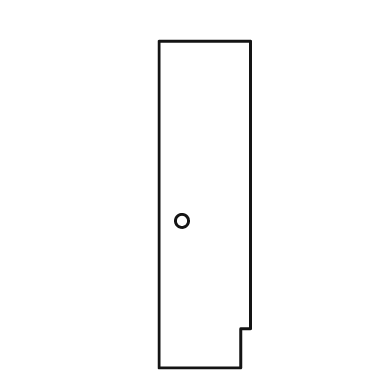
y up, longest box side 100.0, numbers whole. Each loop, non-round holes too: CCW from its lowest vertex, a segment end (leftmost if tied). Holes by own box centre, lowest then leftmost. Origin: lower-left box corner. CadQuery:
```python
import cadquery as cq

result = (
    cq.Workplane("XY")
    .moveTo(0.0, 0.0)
    .lineTo(25.0, 0.0)
    .lineTo(25.0, 12.0)
    .lineTo(28.0, 12.0)
    .lineTo(28.0, 100.0)
    .lineTo(0.0, 100.0)
    .close()
    .moveTo(7.0, 45.0)
    .circle(2.0)
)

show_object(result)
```